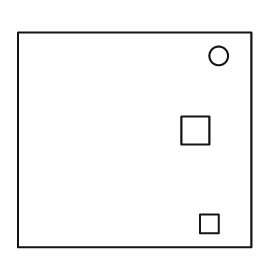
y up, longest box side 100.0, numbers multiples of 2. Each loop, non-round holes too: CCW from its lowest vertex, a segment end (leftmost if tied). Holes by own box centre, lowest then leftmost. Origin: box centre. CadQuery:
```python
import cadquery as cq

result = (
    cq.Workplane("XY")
    .moveTo(-50.0, -46.0)
    .lineTo(50.0, -46.0)
    .lineTo(50.0, 46.0)
    .lineTo(-50.0, 46.0)
    .close()
    .moveTo(28.0, -40.0)
    .lineTo(36.0, -40.0)
    .lineTo(36.0, -32.0)
    .lineTo(28.0, -32.0)
    .close()
    .moveTo(20.0, -2.0)
    .lineTo(32.0, -2.0)
    .lineTo(32.0, 10.0)
    .lineTo(20.0, 10.0)
    .close()
    .moveTo(36.0, 36.0)
    .circle(4.0)
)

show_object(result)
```